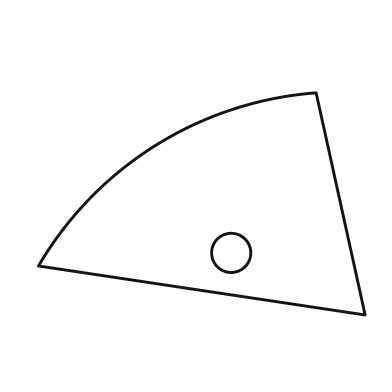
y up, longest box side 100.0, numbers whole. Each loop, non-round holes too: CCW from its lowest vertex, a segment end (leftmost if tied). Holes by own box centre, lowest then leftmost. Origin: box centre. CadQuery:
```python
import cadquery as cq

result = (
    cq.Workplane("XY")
    .moveTo(50.0, -34.0)
    .lineTo(35.0, 34.0)
    .threePointArc((-14.0, 18.0), (-50.0, -19.0))
    .close()
    .moveTo(9.0, -15.0)
    .circle(6.0)
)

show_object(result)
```